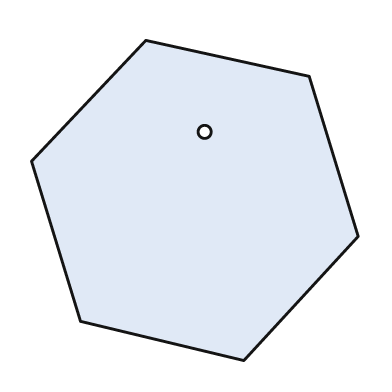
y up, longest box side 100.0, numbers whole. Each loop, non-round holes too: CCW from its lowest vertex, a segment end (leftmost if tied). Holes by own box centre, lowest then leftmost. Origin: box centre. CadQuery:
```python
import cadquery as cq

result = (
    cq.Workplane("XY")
    .moveTo(15.0, -49.0)
    .lineTo(50.0, -11.0)
    .lineTo(35.0, 38.0)
    .lineTo(-15.0, 49.0)
    .lineTo(-50.0, 12.0)
    .lineTo(-35.0, -37.0)
    .close()
    .moveTo(3.0, 21.0)
    .circle(2.0)
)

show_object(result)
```